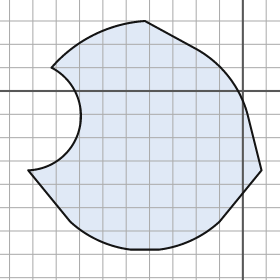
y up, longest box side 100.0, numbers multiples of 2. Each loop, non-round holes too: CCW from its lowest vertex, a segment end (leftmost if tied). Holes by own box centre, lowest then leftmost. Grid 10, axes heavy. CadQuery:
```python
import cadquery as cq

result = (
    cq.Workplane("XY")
    .moveTo(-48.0, -68.0)
    .lineTo(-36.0, -68.0)
    .threePointArc((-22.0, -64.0), (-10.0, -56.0))
    .lineTo(8.0, -34.0)
    .lineTo(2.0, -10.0)
    .threePointArc((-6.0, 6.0), (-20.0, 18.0))
    .lineTo(-42.0, 30.0)
    .threePointArc((-64.0, 24.0), (-82.0, 10.0))
    .threePointArc((-70.0, -16.0), (-92.0, -34.0))
    .lineTo(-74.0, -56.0)
    .threePointArc((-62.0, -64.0), (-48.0, -68.0))
    .close()
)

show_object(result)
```